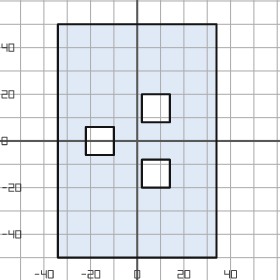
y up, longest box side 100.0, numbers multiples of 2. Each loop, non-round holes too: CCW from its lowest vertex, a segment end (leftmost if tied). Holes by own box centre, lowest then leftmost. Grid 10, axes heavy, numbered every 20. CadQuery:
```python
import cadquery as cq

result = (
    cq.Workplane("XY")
    .moveTo(-34.0, -50.0)
    .lineTo(34.0, -50.0)
    .lineTo(34.0, 50.0)
    .lineTo(-34.0, 50.0)
    .close()
    .moveTo(2.0, -20.0)
    .lineTo(14.0, -20.0)
    .lineTo(14.0, -8.0)
    .lineTo(2.0, -8.0)
    .close()
    .moveTo(-22.0, -6.0)
    .lineTo(-10.0, -6.0)
    .lineTo(-10.0, 6.0)
    .lineTo(-22.0, 6.0)
    .close()
    .moveTo(2.0, 8.0)
    .lineTo(14.0, 8.0)
    .lineTo(14.0, 20.0)
    .lineTo(2.0, 20.0)
    .close()
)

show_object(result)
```